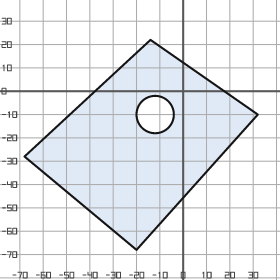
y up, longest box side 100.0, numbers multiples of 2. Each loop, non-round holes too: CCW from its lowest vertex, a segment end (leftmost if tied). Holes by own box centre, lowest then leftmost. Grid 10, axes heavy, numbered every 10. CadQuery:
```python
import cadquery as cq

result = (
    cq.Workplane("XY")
    .moveTo(-20.0, -68.0)
    .lineTo(32.0, -10.0)
    .lineTo(-14.0, 22.0)
    .lineTo(-68.0, -28.0)
    .close()
    .moveTo(-12.0, -10.0)
    .circle(8.0)
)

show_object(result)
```